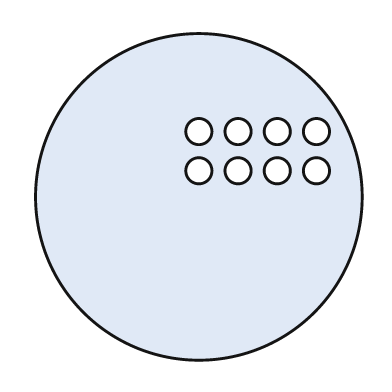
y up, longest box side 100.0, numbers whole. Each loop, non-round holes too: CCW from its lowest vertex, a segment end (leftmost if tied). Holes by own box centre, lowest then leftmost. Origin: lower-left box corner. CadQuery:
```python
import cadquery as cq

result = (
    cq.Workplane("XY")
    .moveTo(50.0, 50.0)
    .circle(50.0)
    .moveTo(50.0, 58.0)
    .circle(4.0)
    .moveTo(62.0, 58.0)
    .circle(4.0)
    .moveTo(74.0, 58.0)
    .circle(4.0)
    .moveTo(86.0, 58.0)
    .circle(4.0)
    .moveTo(50.0, 70.0)
    .circle(4.0)
    .moveTo(62.0, 70.0)
    .circle(4.0)
    .moveTo(74.0, 70.0)
    .circle(4.0)
    .moveTo(86.0, 70.0)
    .circle(4.0)
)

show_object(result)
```